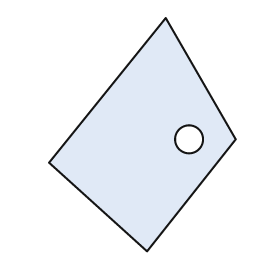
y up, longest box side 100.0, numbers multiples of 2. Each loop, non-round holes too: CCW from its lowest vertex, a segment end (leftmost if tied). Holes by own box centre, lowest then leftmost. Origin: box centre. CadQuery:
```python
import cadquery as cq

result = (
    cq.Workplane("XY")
    .moveTo(2.0, -50.0)
    .lineTo(40.0, -2.0)
    .lineTo(10.0, 50.0)
    .lineTo(-40.0, -12.0)
    .close()
    .moveTo(20.0, -2.0)
    .circle(6.0)
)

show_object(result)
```